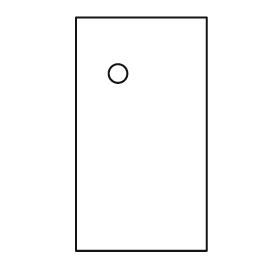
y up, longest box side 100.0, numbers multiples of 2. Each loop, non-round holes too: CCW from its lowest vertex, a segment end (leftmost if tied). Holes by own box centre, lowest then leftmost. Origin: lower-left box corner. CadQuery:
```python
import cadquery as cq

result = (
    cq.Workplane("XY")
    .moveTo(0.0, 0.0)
    .lineTo(56.0, 0.0)
    .lineTo(56.0, 100.0)
    .lineTo(0.0, 100.0)
    .close()
    .moveTo(18.0, 76.0)
    .circle(4.0)
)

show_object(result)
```